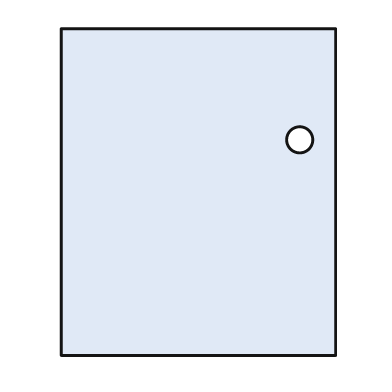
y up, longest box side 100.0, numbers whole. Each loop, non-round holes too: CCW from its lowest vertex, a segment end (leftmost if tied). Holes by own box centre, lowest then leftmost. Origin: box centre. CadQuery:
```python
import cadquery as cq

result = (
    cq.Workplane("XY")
    .moveTo(-42.0, -50.0)
    .lineTo(42.0, -50.0)
    .lineTo(42.0, 50.0)
    .lineTo(-42.0, 50.0)
    .close()
    .moveTo(31.0, 16.0)
    .circle(4.0)
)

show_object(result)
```